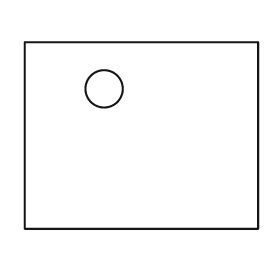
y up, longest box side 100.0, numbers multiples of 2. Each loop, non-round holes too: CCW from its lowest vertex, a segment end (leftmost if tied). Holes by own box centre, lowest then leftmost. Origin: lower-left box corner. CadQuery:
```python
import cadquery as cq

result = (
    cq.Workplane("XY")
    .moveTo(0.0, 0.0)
    .lineTo(100.0, 0.0)
    .lineTo(100.0, 80.0)
    .lineTo(0.0, 80.0)
    .close()
    .moveTo(34.0, 60.0)
    .circle(8.0)
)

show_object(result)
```